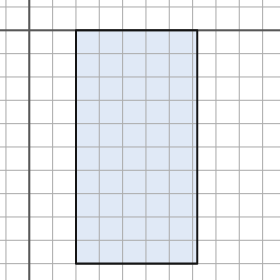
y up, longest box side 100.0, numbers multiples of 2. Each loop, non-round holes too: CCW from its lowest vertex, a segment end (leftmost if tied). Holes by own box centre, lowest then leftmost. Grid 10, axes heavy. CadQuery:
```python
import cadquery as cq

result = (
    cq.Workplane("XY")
    .moveTo(20.0, -100.0)
    .lineTo(72.0, -100.0)
    .lineTo(72.0, 0.0)
    .lineTo(20.0, 0.0)
    .close()
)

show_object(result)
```